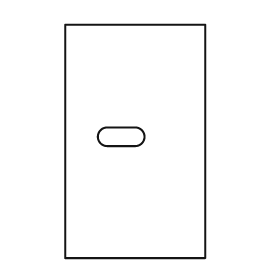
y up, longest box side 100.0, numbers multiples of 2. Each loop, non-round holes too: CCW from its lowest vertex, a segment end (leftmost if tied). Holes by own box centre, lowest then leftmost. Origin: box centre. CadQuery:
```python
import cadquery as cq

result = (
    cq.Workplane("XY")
    .moveTo(-30.0, -50.0)
    .lineTo(30.0, -50.0)
    .lineTo(30.0, 50.0)
    .lineTo(-30.0, 50.0)
    .close()
    .moveTo(-12.0, -2.0)
    .lineTo(0.0, -2.0)
    .threePointArc((4.0, 2.0), (0.0, 6.0))
    .lineTo(-12.0, 6.0)
    .threePointArc((-16.0, 2.0), (-12.0, -2.0))
    .close()
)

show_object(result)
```